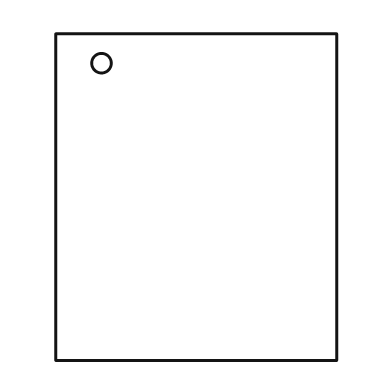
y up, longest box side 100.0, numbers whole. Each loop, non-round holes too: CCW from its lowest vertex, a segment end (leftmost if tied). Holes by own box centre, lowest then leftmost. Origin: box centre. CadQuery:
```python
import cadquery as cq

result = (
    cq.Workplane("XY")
    .moveTo(-43.0, -50.0)
    .lineTo(43.0, -50.0)
    .lineTo(43.0, 50.0)
    .lineTo(-43.0, 50.0)
    .close()
    .moveTo(-29.0, 41.0)
    .circle(3.0)
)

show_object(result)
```